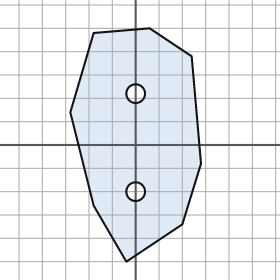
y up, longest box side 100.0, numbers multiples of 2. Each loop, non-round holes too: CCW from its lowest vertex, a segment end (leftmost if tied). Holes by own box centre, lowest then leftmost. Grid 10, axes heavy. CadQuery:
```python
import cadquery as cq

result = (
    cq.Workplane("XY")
    .moveTo(-4.0, -50.0)
    .lineTo(20.0, -34.0)
    .lineTo(28.0, -8.0)
    .lineTo(24.0, 38.0)
    .lineTo(6.0, 50.0)
    .lineTo(-18.0, 48.0)
    .lineTo(-28.0, 14.0)
    .lineTo(-18.0, -26.0)
    .close()
    .moveTo(0.0, -20.0)
    .circle(4.0)
    .moveTo(0.0, 22.0)
    .circle(4.0)
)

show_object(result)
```